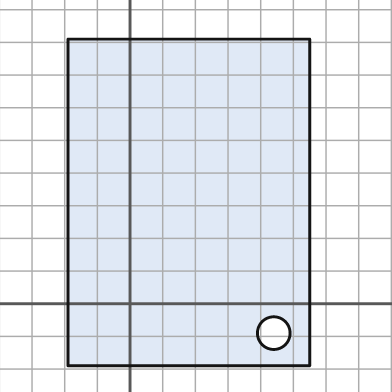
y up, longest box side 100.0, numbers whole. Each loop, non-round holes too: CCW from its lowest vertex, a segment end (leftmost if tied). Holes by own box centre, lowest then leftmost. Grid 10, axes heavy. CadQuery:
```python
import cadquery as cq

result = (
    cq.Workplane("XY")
    .moveTo(-19.0, -19.0)
    .lineTo(55.0, -19.0)
    .lineTo(55.0, 81.0)
    .lineTo(-19.0, 81.0)
    .close()
    .moveTo(44.0, -9.0)
    .circle(5.0)
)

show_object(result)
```